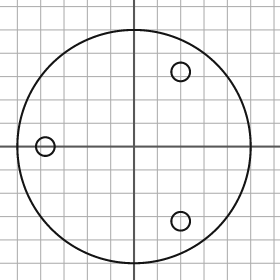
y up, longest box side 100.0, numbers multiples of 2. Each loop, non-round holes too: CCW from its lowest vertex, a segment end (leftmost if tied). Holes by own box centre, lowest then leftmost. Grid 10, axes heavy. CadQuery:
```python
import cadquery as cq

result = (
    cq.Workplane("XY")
    .moveTo(0.0, 0.0)
    .circle(50.0)
    .moveTo(20.0, -32.0)
    .circle(4.0)
    .moveTo(-38.0, 0.0)
    .circle(4.0)
    .moveTo(20.0, 32.0)
    .circle(4.0)
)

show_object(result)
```